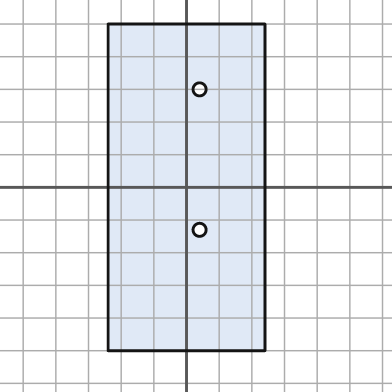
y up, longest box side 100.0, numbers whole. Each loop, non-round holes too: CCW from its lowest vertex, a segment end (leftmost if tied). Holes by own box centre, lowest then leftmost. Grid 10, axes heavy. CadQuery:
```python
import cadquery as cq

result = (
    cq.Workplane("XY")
    .moveTo(-24.0, -50.0)
    .lineTo(24.0, -50.0)
    .lineTo(24.0, 50.0)
    .lineTo(-24.0, 50.0)
    .close()
    .moveTo(4.0, -13.0)
    .circle(2.0)
    .moveTo(4.0, 30.0)
    .circle(2.0)
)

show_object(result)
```